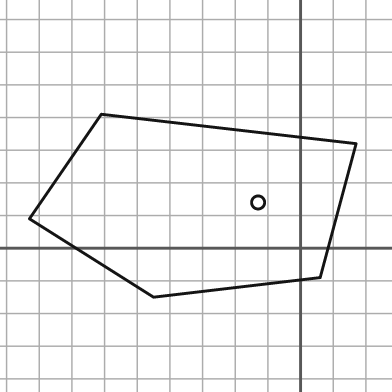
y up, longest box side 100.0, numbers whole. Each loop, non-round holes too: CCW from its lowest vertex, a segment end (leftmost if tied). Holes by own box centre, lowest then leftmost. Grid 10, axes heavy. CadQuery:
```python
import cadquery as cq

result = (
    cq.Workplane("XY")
    .moveTo(-45.0, -15.0)
    .lineTo(6.0, -9.0)
    .lineTo(17.0, 32.0)
    .lineTo(-61.0, 41.0)
    .lineTo(-83.0, 9.0)
    .close()
    .moveTo(-13.0, 14.0)
    .circle(2.0)
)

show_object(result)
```